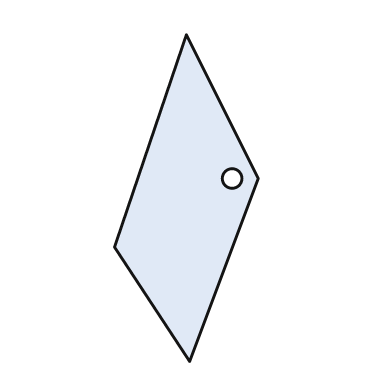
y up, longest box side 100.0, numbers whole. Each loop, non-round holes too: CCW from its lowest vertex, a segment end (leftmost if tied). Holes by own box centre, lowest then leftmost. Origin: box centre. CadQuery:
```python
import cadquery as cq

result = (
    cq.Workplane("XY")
    .moveTo(1.0, -50.0)
    .lineTo(22.0, 6.0)
    .lineTo(0.0, 50.0)
    .lineTo(-22.0, -15.0)
    .close()
    .moveTo(14.0, 6.0)
    .circle(3.0)
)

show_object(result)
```